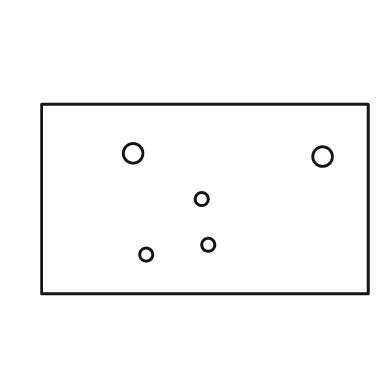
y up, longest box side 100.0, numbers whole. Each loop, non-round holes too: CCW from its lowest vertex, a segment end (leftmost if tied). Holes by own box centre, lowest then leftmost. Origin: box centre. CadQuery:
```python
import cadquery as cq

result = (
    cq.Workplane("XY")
    .moveTo(-50.0, -29.0)
    .lineTo(50.0, -29.0)
    .lineTo(50.0, 29.0)
    .lineTo(-50.0, 29.0)
    .close()
    .moveTo(-18.0, -17.0)
    .circle(2.0)
    .moveTo(1.0, -14.0)
    .circle(2.0)
    .moveTo(-1.0, 0.0)
    .circle(2.0)
    .moveTo(36.0, 13.0)
    .circle(3.0)
    .moveTo(-22.0, 14.0)
    .circle(3.0)
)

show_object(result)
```